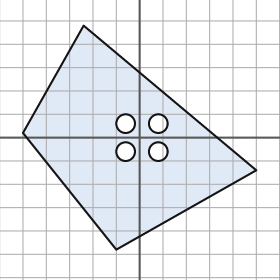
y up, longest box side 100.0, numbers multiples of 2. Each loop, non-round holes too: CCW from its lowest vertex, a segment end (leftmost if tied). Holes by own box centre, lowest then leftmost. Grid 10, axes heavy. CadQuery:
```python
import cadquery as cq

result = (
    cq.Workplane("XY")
    .moveTo(-10.0, -48.0)
    .lineTo(50.0, -14.0)
    .lineTo(-24.0, 48.0)
    .lineTo(-50.0, 2.0)
    .close()
    .moveTo(-6.0, -6.0)
    .circle(4.0)
    .moveTo(8.0, -6.0)
    .circle(4.0)
    .moveTo(-6.0, 6.0)
    .circle(4.0)
    .moveTo(8.0, 6.0)
    .circle(4.0)
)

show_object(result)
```